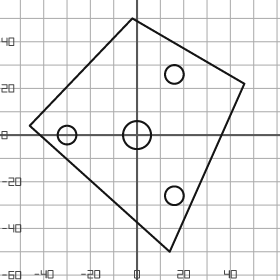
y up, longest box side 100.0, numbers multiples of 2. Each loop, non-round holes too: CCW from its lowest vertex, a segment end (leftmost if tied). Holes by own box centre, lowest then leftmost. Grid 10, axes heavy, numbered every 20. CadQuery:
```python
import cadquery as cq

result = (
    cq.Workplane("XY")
    .moveTo(14.0, -50.0)
    .lineTo(46.0, 22.0)
    .lineTo(-2.0, 50.0)
    .lineTo(-46.0, 4.0)
    .close()
    .moveTo(16.0, -26.0)
    .circle(4.0)
    .moveTo(-30.0, 0.0)
    .circle(4.0)
    .moveTo(0.0, 0.0)
    .circle(6.0)
    .moveTo(16.0, 26.0)
    .circle(4.0)
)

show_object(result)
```